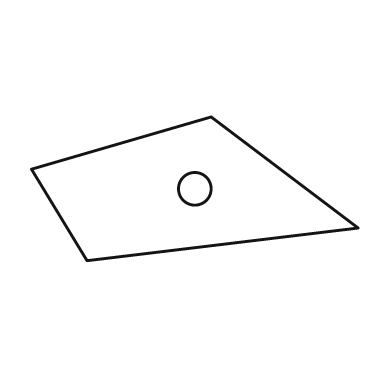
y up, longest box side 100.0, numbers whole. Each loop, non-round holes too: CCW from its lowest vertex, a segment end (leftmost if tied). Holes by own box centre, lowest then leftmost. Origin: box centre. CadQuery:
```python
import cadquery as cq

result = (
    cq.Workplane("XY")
    .moveTo(-33.0, -22.0)
    .lineTo(50.0, -12.0)
    .lineTo(5.0, 22.0)
    .lineTo(-50.0, 6.0)
    .close()
    .moveTo(0.0, 0.0)
    .circle(5.0)
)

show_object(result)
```